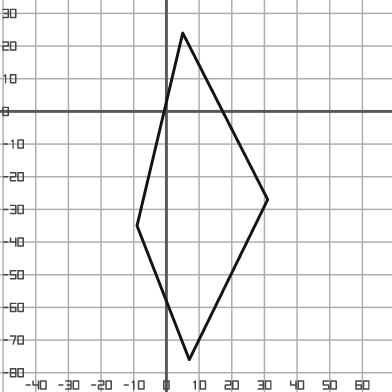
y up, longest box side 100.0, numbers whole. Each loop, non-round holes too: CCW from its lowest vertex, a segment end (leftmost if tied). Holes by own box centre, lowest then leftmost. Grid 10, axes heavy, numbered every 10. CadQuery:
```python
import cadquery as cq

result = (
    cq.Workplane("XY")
    .moveTo(7.0, -76.0)
    .lineTo(31.0, -27.0)
    .lineTo(5.0, 24.0)
    .lineTo(-9.0, -35.0)
    .close()
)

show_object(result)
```